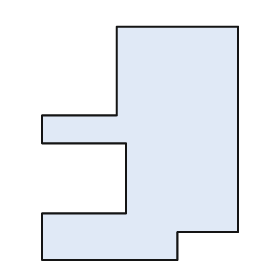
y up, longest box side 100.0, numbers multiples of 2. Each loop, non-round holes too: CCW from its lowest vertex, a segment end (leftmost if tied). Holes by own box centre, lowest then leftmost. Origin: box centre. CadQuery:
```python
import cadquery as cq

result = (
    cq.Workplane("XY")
    .moveTo(-42.0, -50.0)
    .lineTo(16.0, -50.0)
    .lineTo(16.0, -38.0)
    .lineTo(42.0, -38.0)
    .lineTo(42.0, 50.0)
    .lineTo(-10.0, 50.0)
    .lineTo(-10.0, 12.0)
    .lineTo(-42.0, 12.0)
    .lineTo(-42.0, 0.0)
    .lineTo(-6.0, 0.0)
    .lineTo(-6.0, -30.0)
    .lineTo(-42.0, -30.0)
    .close()
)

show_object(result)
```